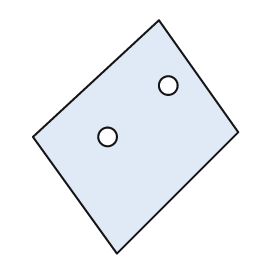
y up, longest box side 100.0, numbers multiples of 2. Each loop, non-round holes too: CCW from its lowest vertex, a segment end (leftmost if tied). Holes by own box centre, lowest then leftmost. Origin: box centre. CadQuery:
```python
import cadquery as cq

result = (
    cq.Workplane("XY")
    .moveTo(-8.0, -50.0)
    .lineTo(44.0, 2.0)
    .lineTo(10.0, 50.0)
    .lineTo(-44.0, 0.0)
    .close()
    .moveTo(-12.0, 0.0)
    .circle(4.0)
    .moveTo(14.0, 22.0)
    .circle(4.0)
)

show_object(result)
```